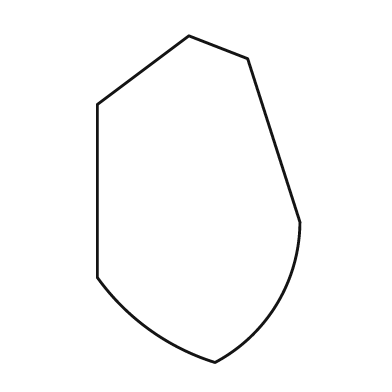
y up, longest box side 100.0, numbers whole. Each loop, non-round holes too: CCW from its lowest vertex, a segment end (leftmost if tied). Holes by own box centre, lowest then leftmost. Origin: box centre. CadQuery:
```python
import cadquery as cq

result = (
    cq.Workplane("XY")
    .moveTo(5.0, -50.0)
    .threePointArc((24.0, -32.0), (31.0, -7.0))
    .lineTo(15.0, 43.0)
    .lineTo(-3.0, 50.0)
    .lineTo(-31.0, 29.0)
    .lineTo(-31.0, -24.0)
    .threePointArc((-15.0, -40.0), (5.0, -50.0))
    .close()
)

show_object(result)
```